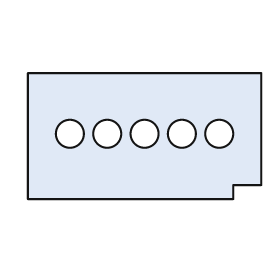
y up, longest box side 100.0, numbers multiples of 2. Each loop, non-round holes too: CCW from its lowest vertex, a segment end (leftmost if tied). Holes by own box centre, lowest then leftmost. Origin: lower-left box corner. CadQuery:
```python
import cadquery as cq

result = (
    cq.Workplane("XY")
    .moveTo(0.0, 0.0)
    .lineTo(88.0, 0.0)
    .lineTo(88.0, 6.0)
    .lineTo(100.0, 6.0)
    .lineTo(100.0, 54.0)
    .lineTo(0.0, 54.0)
    .close()
    .moveTo(18.0, 28.0)
    .circle(6.0)
    .moveTo(34.0, 28.0)
    .circle(6.0)
    .moveTo(50.0, 28.0)
    .circle(6.0)
    .moveTo(66.0, 28.0)
    .circle(6.0)
    .moveTo(82.0, 28.0)
    .circle(6.0)
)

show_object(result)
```